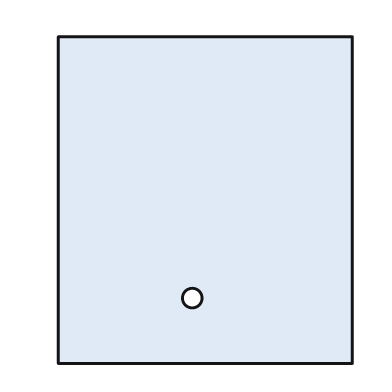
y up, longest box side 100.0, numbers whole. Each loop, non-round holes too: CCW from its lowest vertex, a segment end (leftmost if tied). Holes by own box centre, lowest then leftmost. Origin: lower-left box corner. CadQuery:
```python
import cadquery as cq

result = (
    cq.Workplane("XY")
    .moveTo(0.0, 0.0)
    .lineTo(90.0, 0.0)
    .lineTo(90.0, 100.0)
    .lineTo(0.0, 100.0)
    .close()
    .moveTo(41.0, 20.0)
    .circle(3.0)
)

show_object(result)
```